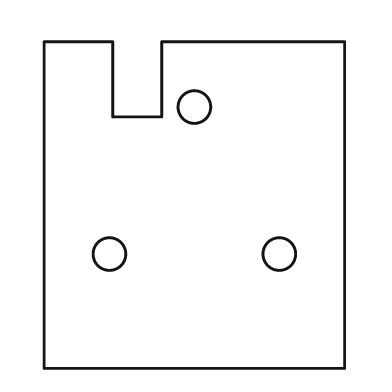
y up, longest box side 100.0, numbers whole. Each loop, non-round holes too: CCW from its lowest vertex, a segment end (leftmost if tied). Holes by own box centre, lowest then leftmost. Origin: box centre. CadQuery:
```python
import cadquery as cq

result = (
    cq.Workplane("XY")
    .moveTo(-46.0, -50.0)
    .lineTo(46.0, -50.0)
    .lineTo(46.0, 50.0)
    .lineTo(-10.0, 50.0)
    .lineTo(-10.0, 27.0)
    .lineTo(-25.0, 27.0)
    .lineTo(-25.0, 50.0)
    .lineTo(-46.0, 50.0)
    .close()
    .moveTo(-26.0, -15.0)
    .circle(5.0)
    .moveTo(26.0, -15.0)
    .circle(5.0)
    .moveTo(0.0, 30.0)
    .circle(5.0)
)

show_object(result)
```